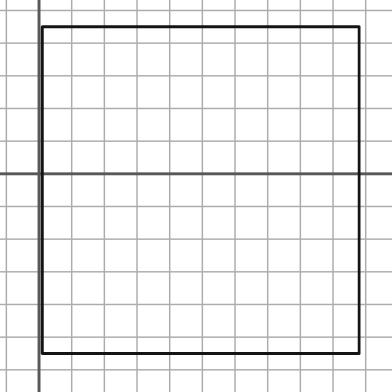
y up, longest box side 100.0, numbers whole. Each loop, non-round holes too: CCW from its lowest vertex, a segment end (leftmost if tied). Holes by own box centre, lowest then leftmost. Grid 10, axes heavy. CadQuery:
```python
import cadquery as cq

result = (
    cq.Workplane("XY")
    .moveTo(1.0, -55.0)
    .lineTo(98.0, -55.0)
    .lineTo(98.0, 45.0)
    .lineTo(1.0, 45.0)
    .close()
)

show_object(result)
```